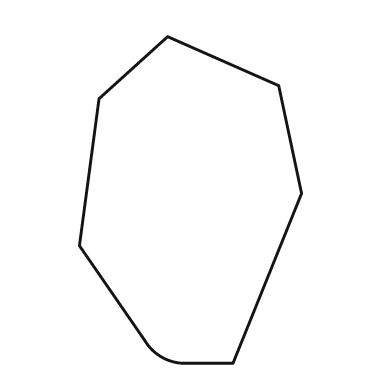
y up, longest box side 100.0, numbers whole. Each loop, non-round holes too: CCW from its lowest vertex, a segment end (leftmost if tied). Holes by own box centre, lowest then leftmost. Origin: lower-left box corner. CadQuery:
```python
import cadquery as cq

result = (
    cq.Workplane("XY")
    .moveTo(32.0, 0.0)
    .lineTo(47.0, 0.0)
    .lineTo(68.0, 52.0)
    .lineTo(61.0, 85.0)
    .lineTo(27.0, 100.0)
    .lineTo(6.0, 81.0)
    .lineTo(0.0, 36.0)
    .lineTo(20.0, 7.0)
    .threePointArc((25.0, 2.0), (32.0, 0.0))
    .close()
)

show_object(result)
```